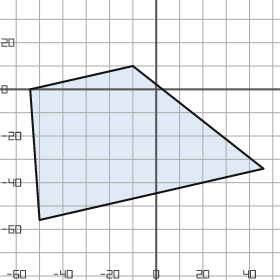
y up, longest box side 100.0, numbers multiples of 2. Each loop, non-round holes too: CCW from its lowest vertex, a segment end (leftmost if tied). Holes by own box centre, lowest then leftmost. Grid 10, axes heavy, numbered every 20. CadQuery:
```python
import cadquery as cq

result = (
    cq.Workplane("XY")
    .moveTo(-50.0, -56.0)
    .lineTo(46.0, -34.0)
    .lineTo(-10.0, 10.0)
    .lineTo(-54.0, 0.0)
    .close()
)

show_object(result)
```